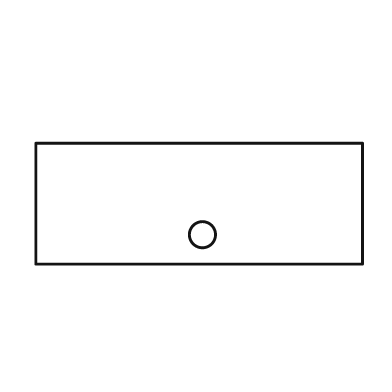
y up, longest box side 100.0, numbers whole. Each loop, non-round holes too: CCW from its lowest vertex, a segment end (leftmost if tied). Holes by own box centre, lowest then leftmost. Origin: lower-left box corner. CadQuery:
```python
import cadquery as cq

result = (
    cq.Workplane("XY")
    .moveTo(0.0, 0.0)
    .lineTo(100.0, 0.0)
    .lineTo(100.0, 37.0)
    .lineTo(0.0, 37.0)
    .close()
    .moveTo(51.0, 9.0)
    .circle(4.0)
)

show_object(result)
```